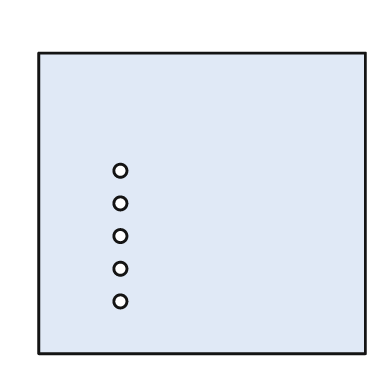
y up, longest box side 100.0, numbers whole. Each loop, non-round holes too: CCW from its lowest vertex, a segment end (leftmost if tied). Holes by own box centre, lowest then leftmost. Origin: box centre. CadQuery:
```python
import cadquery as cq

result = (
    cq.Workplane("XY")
    .moveTo(-50.0, -46.0)
    .lineTo(50.0, -46.0)
    .lineTo(50.0, 46.0)
    .lineTo(-50.0, 46.0)
    .close()
    .moveTo(-25.0, -30.0)
    .circle(2.0)
    .moveTo(-25.0, -20.0)
    .circle(2.0)
    .moveTo(-25.0, -10.0)
    .circle(2.0)
    .moveTo(-25.0, 0.0)
    .circle(2.0)
    .moveTo(-25.0, 10.0)
    .circle(2.0)
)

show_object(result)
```